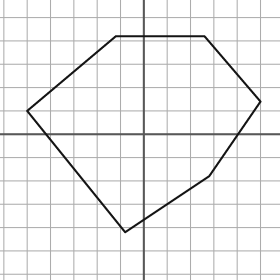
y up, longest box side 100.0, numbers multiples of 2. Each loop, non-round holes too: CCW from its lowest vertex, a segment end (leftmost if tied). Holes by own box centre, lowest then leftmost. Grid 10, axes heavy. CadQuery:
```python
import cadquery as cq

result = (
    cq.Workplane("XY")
    .moveTo(-8.0, -42.0)
    .lineTo(28.0, -18.0)
    .lineTo(50.0, 14.0)
    .lineTo(26.0, 42.0)
    .lineTo(-12.0, 42.0)
    .lineTo(-50.0, 10.0)
    .close()
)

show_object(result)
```